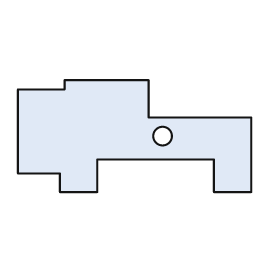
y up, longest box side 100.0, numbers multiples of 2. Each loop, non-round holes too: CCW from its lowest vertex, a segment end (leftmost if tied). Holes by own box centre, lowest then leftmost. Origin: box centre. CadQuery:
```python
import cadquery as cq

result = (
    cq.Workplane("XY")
    .moveTo(-32.0, -24.0)
    .lineTo(-16.0, -24.0)
    .lineTo(-16.0, -10.0)
    .lineTo(34.0, -10.0)
    .lineTo(34.0, -24.0)
    .lineTo(50.0, -24.0)
    .lineTo(50.0, 8.0)
    .lineTo(6.0, 8.0)
    .lineTo(6.0, 24.0)
    .lineTo(-30.0, 24.0)
    .lineTo(-30.0, 20.0)
    .lineTo(-50.0, 20.0)
    .lineTo(-50.0, -16.0)
    .lineTo(-32.0, -16.0)
    .close()
    .moveTo(12.0, 0.0)
    .circle(4.0)
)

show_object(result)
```